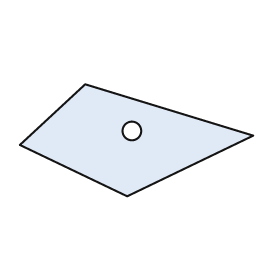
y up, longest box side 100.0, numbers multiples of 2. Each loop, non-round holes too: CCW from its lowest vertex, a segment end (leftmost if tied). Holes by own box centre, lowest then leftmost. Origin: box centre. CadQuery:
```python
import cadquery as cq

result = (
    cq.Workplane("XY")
    .moveTo(-4.0, -24.0)
    .lineTo(50.0, 2.0)
    .lineTo(-22.0, 24.0)
    .lineTo(-50.0, -2.0)
    .close()
    .moveTo(-2.0, 4.0)
    .circle(4.0)
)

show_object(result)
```